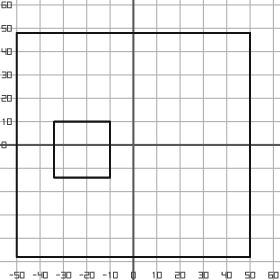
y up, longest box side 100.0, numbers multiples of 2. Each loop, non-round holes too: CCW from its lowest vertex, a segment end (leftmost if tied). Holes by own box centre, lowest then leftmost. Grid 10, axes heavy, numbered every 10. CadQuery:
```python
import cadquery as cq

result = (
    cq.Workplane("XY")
    .moveTo(-50.0, -48.0)
    .lineTo(50.0, -48.0)
    .lineTo(50.0, 48.0)
    .lineTo(-50.0, 48.0)
    .close()
    .moveTo(-34.0, -14.0)
    .lineTo(-10.0, -14.0)
    .lineTo(-10.0, 10.0)
    .lineTo(-34.0, 10.0)
    .close()
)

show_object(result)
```